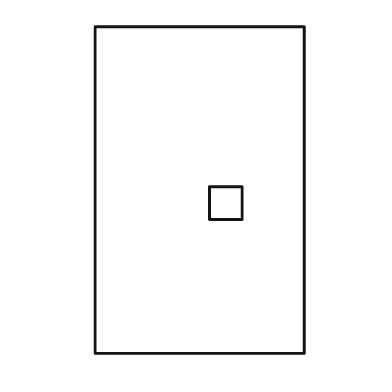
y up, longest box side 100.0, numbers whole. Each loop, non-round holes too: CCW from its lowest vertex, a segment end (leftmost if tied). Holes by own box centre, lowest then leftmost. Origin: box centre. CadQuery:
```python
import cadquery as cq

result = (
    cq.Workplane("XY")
    .moveTo(-32.0, -50.0)
    .lineTo(32.0, -50.0)
    .lineTo(32.0, 50.0)
    .lineTo(-32.0, 50.0)
    .close()
    .moveTo(3.0, -9.0)
    .lineTo(13.0, -9.0)
    .lineTo(13.0, 1.0)
    .lineTo(3.0, 1.0)
    .close()
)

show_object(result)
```